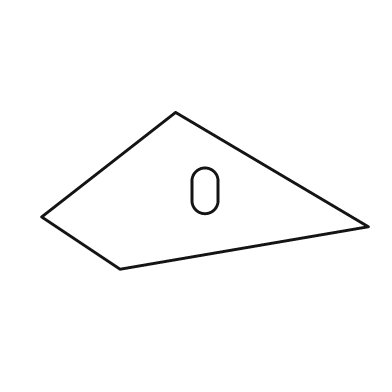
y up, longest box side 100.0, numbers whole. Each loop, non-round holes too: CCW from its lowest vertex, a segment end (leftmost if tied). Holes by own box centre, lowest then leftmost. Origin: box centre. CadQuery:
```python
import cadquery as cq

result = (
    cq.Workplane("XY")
    .moveTo(-26.0, -24.0)
    .lineTo(50.0, -11.0)
    .lineTo(-9.0, 24.0)
    .lineTo(-50.0, -8.0)
    .close()
    .moveTo(-4.0, -3.0)
    .threePointArc((0.0, -7.0), (4.0, -3.0))
    .lineTo(4.0, 3.0)
    .threePointArc((0.0, 7.0), (-4.0, 3.0))
    .close()
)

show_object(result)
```